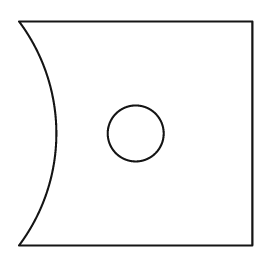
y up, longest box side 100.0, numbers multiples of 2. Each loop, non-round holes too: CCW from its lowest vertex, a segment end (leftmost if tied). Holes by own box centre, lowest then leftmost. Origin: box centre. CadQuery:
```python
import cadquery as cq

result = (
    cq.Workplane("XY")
    .moveTo(-50.0, -48.0)
    .lineTo(50.0, -48.0)
    .lineTo(50.0, 48.0)
    .lineTo(-50.0, 48.0)
    .threePointArc((-34.0, 0.0), (-50.0, -48.0))
    .close()
    .moveTo(0.0, 0.0)
    .circle(12.0)
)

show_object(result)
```